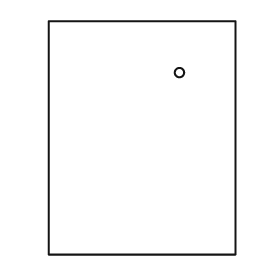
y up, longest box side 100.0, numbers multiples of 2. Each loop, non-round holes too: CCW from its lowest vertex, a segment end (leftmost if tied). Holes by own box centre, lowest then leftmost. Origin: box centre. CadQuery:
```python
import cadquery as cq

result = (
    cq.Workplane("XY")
    .moveTo(-40.0, -50.0)
    .lineTo(40.0, -50.0)
    .lineTo(40.0, 50.0)
    .lineTo(-40.0, 50.0)
    .close()
    .moveTo(16.0, 28.0)
    .circle(2.0)
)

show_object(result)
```